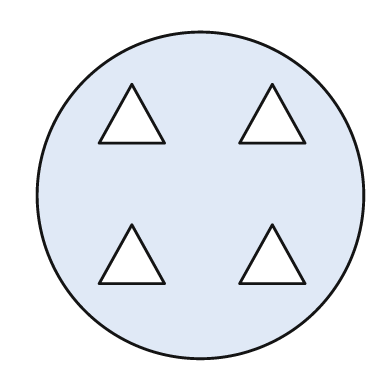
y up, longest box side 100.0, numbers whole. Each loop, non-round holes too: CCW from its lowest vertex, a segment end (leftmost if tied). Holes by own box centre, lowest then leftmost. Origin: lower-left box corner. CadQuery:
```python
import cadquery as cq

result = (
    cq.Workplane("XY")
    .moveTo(50.0, 50.0)
    .circle(50.0)
    .moveTo(19.0, 23.0)
    .lineTo(39.0, 23.0)
    .lineTo(29.0, 41.0)
    .close()
    .moveTo(62.0, 23.0)
    .lineTo(82.0, 23.0)
    .lineTo(72.0, 41.0)
    .close()
    .moveTo(19.0, 66.0)
    .lineTo(39.0, 66.0)
    .lineTo(29.0, 84.0)
    .close()
    .moveTo(62.0, 66.0)
    .lineTo(82.0, 66.0)
    .lineTo(72.0, 84.0)
    .close()
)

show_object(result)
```